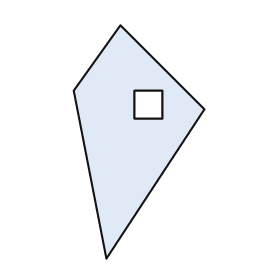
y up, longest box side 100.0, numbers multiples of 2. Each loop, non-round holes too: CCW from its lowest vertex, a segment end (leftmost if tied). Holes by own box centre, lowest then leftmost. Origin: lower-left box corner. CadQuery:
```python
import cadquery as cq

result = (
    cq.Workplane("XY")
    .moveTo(14.0, 0.0)
    .lineTo(56.0, 64.0)
    .lineTo(20.0, 100.0)
    .lineTo(0.0, 72.0)
    .close()
    .moveTo(26.0, 60.0)
    .lineTo(38.0, 60.0)
    .lineTo(38.0, 72.0)
    .lineTo(26.0, 72.0)
    .close()
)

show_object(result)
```